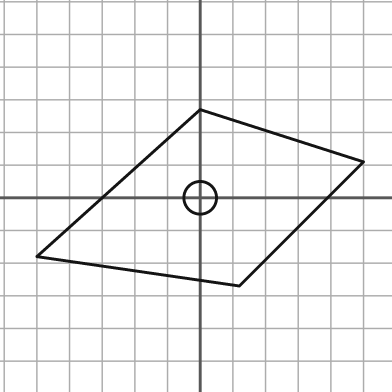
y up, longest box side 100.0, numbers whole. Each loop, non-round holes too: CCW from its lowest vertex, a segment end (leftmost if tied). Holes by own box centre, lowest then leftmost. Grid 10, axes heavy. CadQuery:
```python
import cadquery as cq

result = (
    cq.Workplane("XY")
    .moveTo(12.0, -27.0)
    .lineTo(50.0, 11.0)
    .lineTo(0.0, 27.0)
    .lineTo(-50.0, -18.0)
    .close()
    .moveTo(0.0, 0.0)
    .circle(5.0)
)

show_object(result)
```